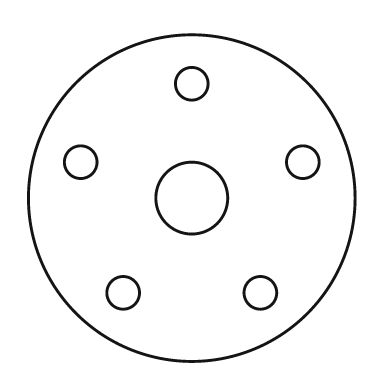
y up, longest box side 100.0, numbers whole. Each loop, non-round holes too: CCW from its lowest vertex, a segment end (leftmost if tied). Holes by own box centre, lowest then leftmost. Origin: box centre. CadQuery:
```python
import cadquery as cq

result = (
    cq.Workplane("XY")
    .moveTo(0.0, 0.0)
    .circle(50.0)
    .moveTo(-21.0, -29.0)
    .circle(5.0)
    .moveTo(21.0, -29.0)
    .circle(5.0)
    .moveTo(0.0, 0.0)
    .circle(11.0)
    .moveTo(-34.0, 11.0)
    .circle(5.0)
    .moveTo(34.0, 11.0)
    .circle(5.0)
    .moveTo(0.0, 35.0)
    .circle(5.0)
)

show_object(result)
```